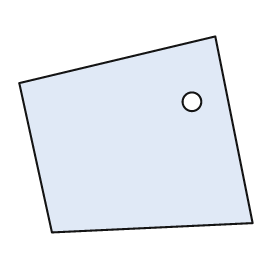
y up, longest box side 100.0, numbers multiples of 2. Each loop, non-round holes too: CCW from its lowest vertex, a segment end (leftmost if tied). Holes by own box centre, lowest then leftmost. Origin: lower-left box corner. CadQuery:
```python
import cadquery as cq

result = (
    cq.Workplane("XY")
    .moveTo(14.0, 0.0)
    .lineTo(100.0, 4.0)
    .lineTo(84.0, 84.0)
    .lineTo(0.0, 64.0)
    .close()
    .moveTo(74.0, 56.0)
    .circle(4.0)
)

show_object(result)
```